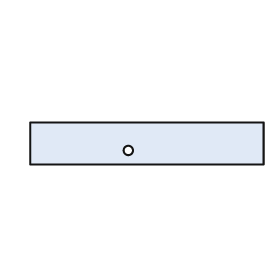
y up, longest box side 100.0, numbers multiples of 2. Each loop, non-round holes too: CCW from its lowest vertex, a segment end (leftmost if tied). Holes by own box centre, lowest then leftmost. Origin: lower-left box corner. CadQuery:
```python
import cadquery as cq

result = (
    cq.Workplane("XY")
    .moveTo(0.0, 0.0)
    .lineTo(100.0, 0.0)
    .lineTo(100.0, 18.0)
    .lineTo(0.0, 18.0)
    .close()
    .moveTo(42.0, 6.0)
    .circle(2.0)
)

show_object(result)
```